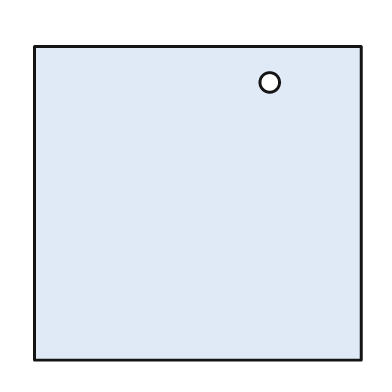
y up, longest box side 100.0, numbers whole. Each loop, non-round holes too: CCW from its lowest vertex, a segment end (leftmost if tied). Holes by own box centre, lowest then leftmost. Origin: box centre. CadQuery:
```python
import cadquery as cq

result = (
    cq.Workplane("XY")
    .moveTo(-50.0, -48.0)
    .lineTo(50.0, -48.0)
    .lineTo(50.0, 48.0)
    .lineTo(-50.0, 48.0)
    .close()
    .moveTo(22.0, 37.0)
    .circle(3.0)
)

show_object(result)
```